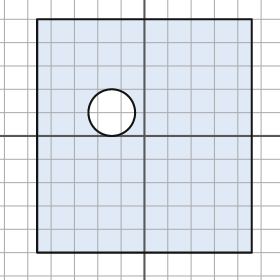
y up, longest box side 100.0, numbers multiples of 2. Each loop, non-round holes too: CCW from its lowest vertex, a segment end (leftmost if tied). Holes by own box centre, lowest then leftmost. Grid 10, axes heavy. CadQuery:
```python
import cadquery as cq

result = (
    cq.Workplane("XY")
    .moveTo(-46.0, -50.0)
    .lineTo(46.0, -50.0)
    .lineTo(46.0, 50.0)
    .lineTo(-46.0, 50.0)
    .close()
    .moveTo(-14.0, 10.0)
    .circle(10.0)
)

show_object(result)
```